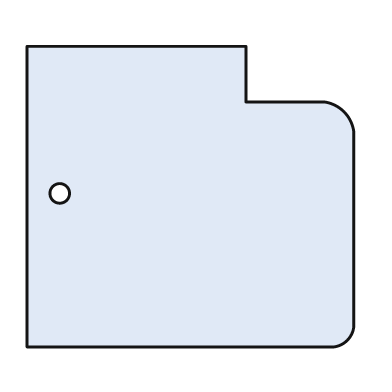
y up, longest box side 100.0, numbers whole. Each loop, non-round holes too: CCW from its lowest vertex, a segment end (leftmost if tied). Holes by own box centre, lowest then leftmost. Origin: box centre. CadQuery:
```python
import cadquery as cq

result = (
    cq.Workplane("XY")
    .moveTo(-50.0, -46.0)
    .lineTo(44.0, -46.0)
    .threePointArc((48.0, -44.0), (50.0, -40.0))
    .lineTo(50.0, 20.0)
    .threePointArc((47.0, 26.0), (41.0, 29.0))
    .lineTo(17.0, 29.0)
    .lineTo(17.0, 46.0)
    .lineTo(-50.0, 46.0)
    .close()
    .moveTo(-40.0, 1.0)
    .circle(3.0)
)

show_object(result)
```